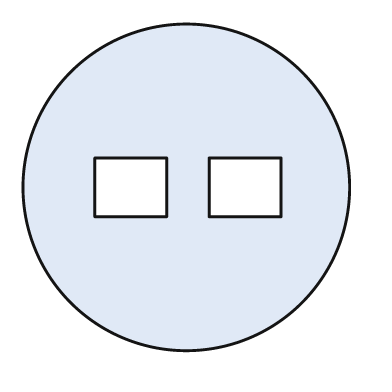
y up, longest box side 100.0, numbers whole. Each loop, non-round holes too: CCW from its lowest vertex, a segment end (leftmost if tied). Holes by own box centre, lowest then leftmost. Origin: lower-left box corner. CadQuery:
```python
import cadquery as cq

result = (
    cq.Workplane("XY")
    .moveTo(50.0, 50.0)
    .circle(50.0)
    .moveTo(22.0, 41.0)
    .lineTo(44.0, 41.0)
    .lineTo(44.0, 59.0)
    .lineTo(22.0, 59.0)
    .close()
    .moveTo(57.0, 41.0)
    .lineTo(79.0, 41.0)
    .lineTo(79.0, 59.0)
    .lineTo(57.0, 59.0)
    .close()
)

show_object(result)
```